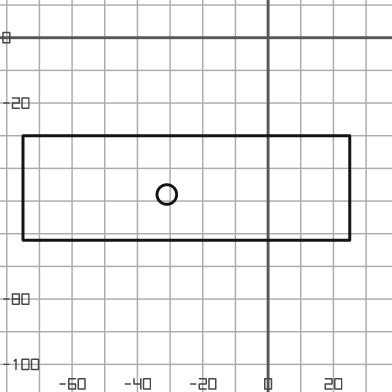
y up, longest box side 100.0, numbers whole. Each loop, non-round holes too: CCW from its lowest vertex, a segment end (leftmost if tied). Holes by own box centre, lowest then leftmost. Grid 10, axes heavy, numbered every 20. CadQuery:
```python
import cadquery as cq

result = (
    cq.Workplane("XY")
    .moveTo(-75.0, -62.0)
    .lineTo(25.0, -62.0)
    .lineTo(25.0, -30.0)
    .lineTo(-75.0, -30.0)
    .close()
    .moveTo(-31.0, -48.0)
    .circle(3.0)
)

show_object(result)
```